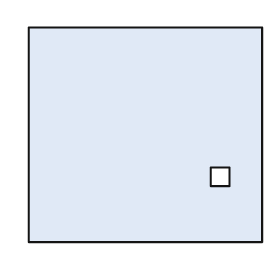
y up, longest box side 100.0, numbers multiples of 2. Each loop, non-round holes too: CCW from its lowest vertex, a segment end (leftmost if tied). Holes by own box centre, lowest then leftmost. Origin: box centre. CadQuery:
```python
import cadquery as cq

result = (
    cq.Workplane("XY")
    .moveTo(-50.0, -46.0)
    .lineTo(50.0, -46.0)
    .lineTo(50.0, 46.0)
    .lineTo(-50.0, 46.0)
    .close()
    .moveTo(28.0, -22.0)
    .lineTo(36.0, -22.0)
    .lineTo(36.0, -14.0)
    .lineTo(28.0, -14.0)
    .close()
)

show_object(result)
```